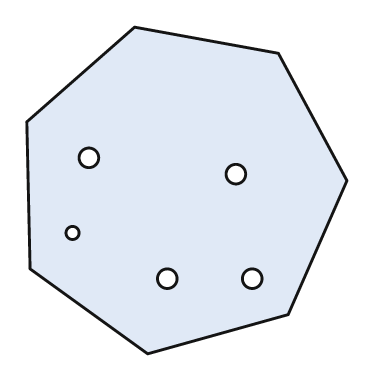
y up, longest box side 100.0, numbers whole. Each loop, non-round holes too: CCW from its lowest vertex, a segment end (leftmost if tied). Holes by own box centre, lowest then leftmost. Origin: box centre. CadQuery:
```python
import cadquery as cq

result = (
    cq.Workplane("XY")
    .moveTo(-12.0, -50.0)
    .lineTo(31.0, -38.0)
    .lineTo(49.0, 3.0)
    .lineTo(28.0, 42.0)
    .lineTo(-16.0, 50.0)
    .lineTo(-49.0, 21.0)
    .lineTo(-48.0, -24.0)
    .close()
    .moveTo(-6.0, -27.0)
    .circle(3.0)
    .moveTo(20.0, -27.0)
    .circle(3.0)
    .moveTo(-35.0, -13.0)
    .circle(2.0)
    .moveTo(15.0, 5.0)
    .circle(3.0)
    .moveTo(-30.0, 10.0)
    .circle(3.0)
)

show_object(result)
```